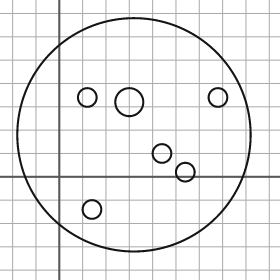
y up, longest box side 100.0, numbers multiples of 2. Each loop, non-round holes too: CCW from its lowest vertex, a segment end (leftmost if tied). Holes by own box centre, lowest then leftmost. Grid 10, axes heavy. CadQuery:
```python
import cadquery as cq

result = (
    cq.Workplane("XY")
    .moveTo(32.0, 18.0)
    .circle(50.0)
    .moveTo(14.0, -14.0)
    .circle(4.0)
    .moveTo(54.0, 2.0)
    .circle(4.0)
    .moveTo(44.0, 10.0)
    .circle(4.0)
    .moveTo(30.0, 32.0)
    .circle(6.0)
    .moveTo(12.0, 34.0)
    .circle(4.0)
    .moveTo(68.0, 34.0)
    .circle(4.0)
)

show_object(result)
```